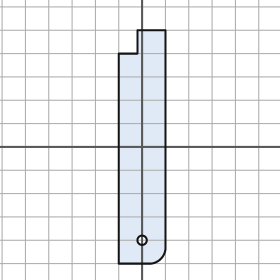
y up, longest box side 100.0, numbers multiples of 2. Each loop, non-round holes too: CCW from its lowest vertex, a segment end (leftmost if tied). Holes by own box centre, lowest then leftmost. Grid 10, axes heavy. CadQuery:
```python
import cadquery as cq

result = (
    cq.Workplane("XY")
    .moveTo(-10.0, -50.0)
    .lineTo(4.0, -50.0)
    .threePointArc((8.0, -48.0), (10.0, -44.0))
    .lineTo(10.0, 50.0)
    .lineTo(-2.0, 50.0)
    .lineTo(-2.0, 40.0)
    .lineTo(-10.0, 40.0)
    .close()
    .moveTo(0.0, -40.0)
    .circle(2.0)
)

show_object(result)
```